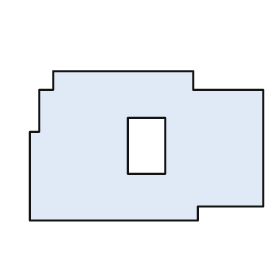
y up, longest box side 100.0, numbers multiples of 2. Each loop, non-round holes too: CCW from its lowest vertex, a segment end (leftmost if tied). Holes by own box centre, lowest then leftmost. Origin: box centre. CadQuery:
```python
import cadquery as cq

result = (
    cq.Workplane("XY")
    .moveTo(-50.0, -32.0)
    .lineTo(22.0, -32.0)
    .lineTo(22.0, -26.0)
    .lineTo(50.0, -26.0)
    .lineTo(50.0, 24.0)
    .lineTo(20.0, 24.0)
    .lineTo(20.0, 32.0)
    .lineTo(-40.0, 32.0)
    .lineTo(-40.0, 24.0)
    .lineTo(-46.0, 24.0)
    .lineTo(-46.0, 6.0)
    .lineTo(-50.0, 6.0)
    .close()
    .moveTo(-8.0, -12.0)
    .lineTo(8.0, -12.0)
    .lineTo(8.0, 12.0)
    .lineTo(-8.0, 12.0)
    .close()
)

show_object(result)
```